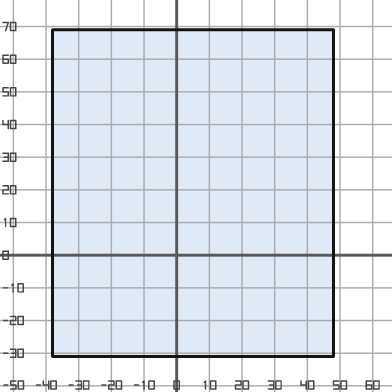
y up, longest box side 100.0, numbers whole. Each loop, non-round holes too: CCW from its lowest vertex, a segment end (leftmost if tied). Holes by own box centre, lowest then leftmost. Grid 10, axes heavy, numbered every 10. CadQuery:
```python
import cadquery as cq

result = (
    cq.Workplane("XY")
    .moveTo(-38.0, -31.0)
    .lineTo(48.0, -31.0)
    .lineTo(48.0, 69.0)
    .lineTo(-38.0, 69.0)
    .close()
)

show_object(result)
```